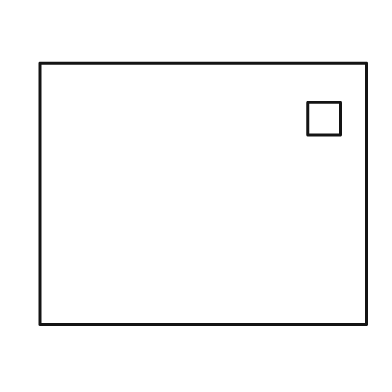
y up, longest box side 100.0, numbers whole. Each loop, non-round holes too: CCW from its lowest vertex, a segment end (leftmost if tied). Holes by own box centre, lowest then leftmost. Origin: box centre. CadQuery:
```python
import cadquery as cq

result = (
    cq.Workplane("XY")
    .moveTo(-50.0, -40.0)
    .lineTo(50.0, -40.0)
    .lineTo(50.0, 40.0)
    .lineTo(-50.0, 40.0)
    .close()
    .moveTo(32.0, 18.0)
    .lineTo(42.0, 18.0)
    .lineTo(42.0, 28.0)
    .lineTo(32.0, 28.0)
    .close()
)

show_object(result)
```